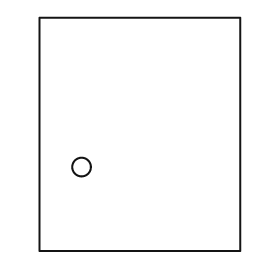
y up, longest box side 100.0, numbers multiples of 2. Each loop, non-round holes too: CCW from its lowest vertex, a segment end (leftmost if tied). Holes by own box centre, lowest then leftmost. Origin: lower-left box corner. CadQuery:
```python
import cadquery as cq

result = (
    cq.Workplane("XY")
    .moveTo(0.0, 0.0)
    .lineTo(86.0, 0.0)
    .lineTo(86.0, 100.0)
    .lineTo(0.0, 100.0)
    .close()
    .moveTo(18.0, 36.0)
    .circle(4.0)
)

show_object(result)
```